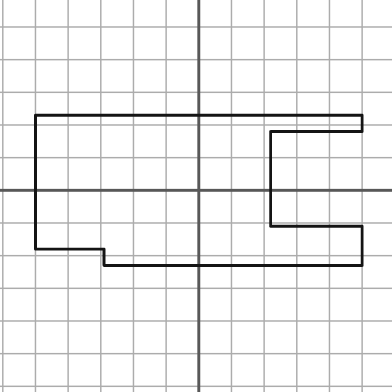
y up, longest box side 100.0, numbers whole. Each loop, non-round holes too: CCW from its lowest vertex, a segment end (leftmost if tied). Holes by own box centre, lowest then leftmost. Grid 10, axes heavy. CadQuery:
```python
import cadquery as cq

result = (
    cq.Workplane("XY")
    .moveTo(-29.0, -23.0)
    .lineTo(50.0, -23.0)
    .lineTo(50.0, -11.0)
    .lineTo(22.0, -11.0)
    .lineTo(22.0, 18.0)
    .lineTo(50.0, 18.0)
    .lineTo(50.0, 23.0)
    .lineTo(-50.0, 23.0)
    .lineTo(-50.0, -18.0)
    .lineTo(-29.0, -18.0)
    .close()
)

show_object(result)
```